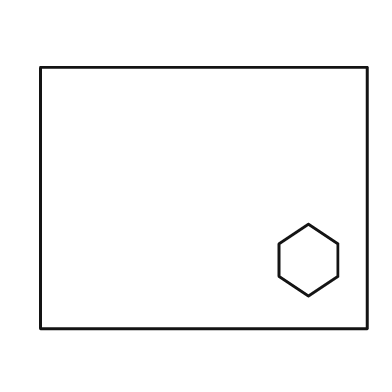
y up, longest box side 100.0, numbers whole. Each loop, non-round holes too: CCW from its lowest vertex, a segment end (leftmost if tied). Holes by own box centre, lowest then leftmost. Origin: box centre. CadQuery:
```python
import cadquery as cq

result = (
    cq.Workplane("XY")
    .moveTo(-50.0, -40.0)
    .lineTo(50.0, -40.0)
    .lineTo(50.0, 40.0)
    .lineTo(-50.0, 40.0)
    .close()
    .moveTo(32.0, -30.0)
    .lineTo(41.0, -24.0)
    .lineTo(41.0, -14.0)
    .lineTo(32.0, -8.0)
    .lineTo(23.0, -14.0)
    .lineTo(23.0, -24.0)
    .close()
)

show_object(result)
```